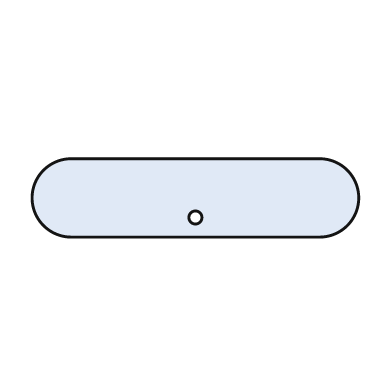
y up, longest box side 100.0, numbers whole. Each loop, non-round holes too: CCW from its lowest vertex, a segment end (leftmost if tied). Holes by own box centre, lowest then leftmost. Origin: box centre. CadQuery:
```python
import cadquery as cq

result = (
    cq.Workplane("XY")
    .moveTo(-38.0, -12.0)
    .lineTo(38.0, -12.0)
    .threePointArc((50.0, 0.0), (38.0, 12.0))
    .lineTo(-38.0, 12.0)
    .threePointArc((-50.0, 0.0), (-38.0, -12.0))
    .close()
    .moveTo(0.0, -6.0)
    .circle(2.0)
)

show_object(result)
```